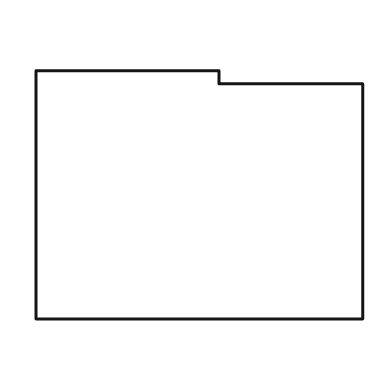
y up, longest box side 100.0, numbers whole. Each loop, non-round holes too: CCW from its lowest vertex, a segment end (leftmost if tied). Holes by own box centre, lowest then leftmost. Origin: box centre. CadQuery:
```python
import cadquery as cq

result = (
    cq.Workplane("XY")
    .moveTo(-50.0, -38.0)
    .lineTo(50.0, -38.0)
    .lineTo(50.0, 34.0)
    .lineTo(6.0, 34.0)
    .lineTo(6.0, 38.0)
    .lineTo(-50.0, 38.0)
    .close()
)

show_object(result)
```